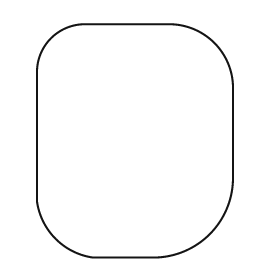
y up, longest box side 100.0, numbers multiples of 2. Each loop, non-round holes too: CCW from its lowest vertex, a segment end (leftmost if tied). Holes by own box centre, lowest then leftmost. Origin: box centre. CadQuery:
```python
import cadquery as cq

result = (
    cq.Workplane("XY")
    .moveTo(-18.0, -50.0)
    .lineTo(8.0, -50.0)
    .threePointArc((32.0, -40.0), (42.0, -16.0))
    .lineTo(42.0, 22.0)
    .threePointArc((34.0, 42.0), (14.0, 50.0))
    .lineTo(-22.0, 50.0)
    .threePointArc((-36.0, 44.0), (-42.0, 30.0))
    .lineTo(-42.0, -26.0)
    .threePointArc((-34.0, -42.0), (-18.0, -50.0))
    .close()
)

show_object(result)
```